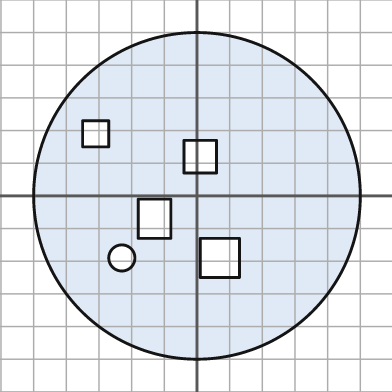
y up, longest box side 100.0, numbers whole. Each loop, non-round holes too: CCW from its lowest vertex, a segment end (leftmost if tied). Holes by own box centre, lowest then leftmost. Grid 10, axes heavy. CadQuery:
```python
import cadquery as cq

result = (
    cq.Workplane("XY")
    .moveTo(0.0, 0.0)
    .circle(50.0)
    .moveTo(-23.0, -19.0)
    .circle(4.0)
    .moveTo(1.0, -25.0)
    .lineTo(13.0, -25.0)
    .lineTo(13.0, -13.0)
    .lineTo(1.0, -13.0)
    .close()
    .moveTo(-18.0, -13.0)
    .lineTo(-8.0, -13.0)
    .lineTo(-8.0, -1.0)
    .lineTo(-18.0, -1.0)
    .close()
    .moveTo(-4.0, 7.0)
    .lineTo(6.0, 7.0)
    .lineTo(6.0, 17.0)
    .lineTo(-4.0, 17.0)
    .close()
    .moveTo(-35.0, 15.0)
    .lineTo(-27.0, 15.0)
    .lineTo(-27.0, 23.0)
    .lineTo(-35.0, 23.0)
    .close()
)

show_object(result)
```